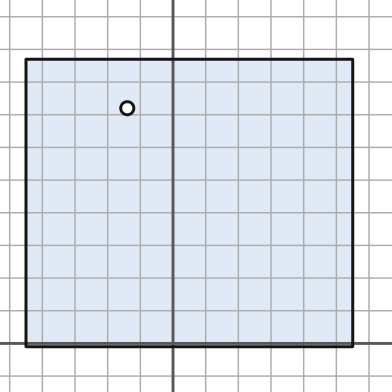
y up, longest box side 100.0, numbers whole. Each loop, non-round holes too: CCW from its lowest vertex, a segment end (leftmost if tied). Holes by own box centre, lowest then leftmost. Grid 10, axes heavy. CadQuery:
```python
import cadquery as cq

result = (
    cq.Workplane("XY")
    .moveTo(-45.0, -1.0)
    .lineTo(55.0, -1.0)
    .lineTo(55.0, 87.0)
    .lineTo(-45.0, 87.0)
    .close()
    .moveTo(-14.0, 72.0)
    .circle(2.0)
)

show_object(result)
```